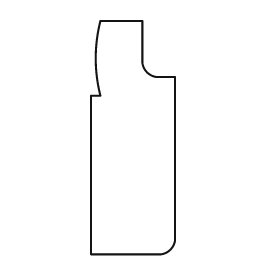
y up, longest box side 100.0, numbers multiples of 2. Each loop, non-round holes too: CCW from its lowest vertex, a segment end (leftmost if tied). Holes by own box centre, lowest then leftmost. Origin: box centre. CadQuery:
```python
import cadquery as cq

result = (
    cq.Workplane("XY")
    .moveTo(-18.0, -50.0)
    .lineTo(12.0, -50.0)
    .threePointArc((16.0, -48.0), (18.0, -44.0))
    .lineTo(18.0, 26.0)
    .lineTo(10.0, 26.0)
    .threePointArc((6.0, 28.0), (4.0, 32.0))
    .lineTo(4.0, 50.0)
    .lineTo(-14.0, 50.0)
    .threePointArc((-16.0, 34.0), (-14.0, 18.0))
    .lineTo(-18.0, 18.0)
    .close()
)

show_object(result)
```